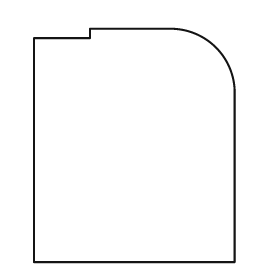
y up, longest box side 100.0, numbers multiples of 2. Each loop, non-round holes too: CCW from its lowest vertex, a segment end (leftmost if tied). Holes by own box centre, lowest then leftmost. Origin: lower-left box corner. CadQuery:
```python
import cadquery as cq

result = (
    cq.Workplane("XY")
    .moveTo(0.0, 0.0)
    .lineTo(86.0, 0.0)
    .lineTo(86.0, 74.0)
    .threePointArc((78.0, 92.0), (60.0, 100.0))
    .lineTo(24.0, 100.0)
    .lineTo(24.0, 96.0)
    .lineTo(0.0, 96.0)
    .close()
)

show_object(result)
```